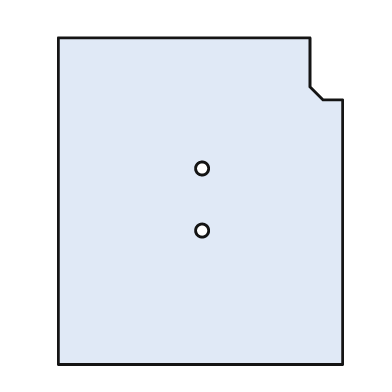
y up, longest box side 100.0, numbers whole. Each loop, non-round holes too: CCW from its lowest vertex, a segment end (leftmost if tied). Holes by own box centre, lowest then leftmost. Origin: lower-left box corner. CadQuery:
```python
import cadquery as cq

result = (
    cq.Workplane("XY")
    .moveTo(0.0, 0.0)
    .lineTo(87.0, 0.0)
    .lineTo(87.0, 81.0)
    .lineTo(81.0, 81.0)
    .lineTo(77.0, 85.0)
    .lineTo(77.0, 100.0)
    .lineTo(0.0, 100.0)
    .close()
    .moveTo(44.0, 41.0)
    .circle(2.0)
    .moveTo(44.0, 60.0)
    .circle(2.0)
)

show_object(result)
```